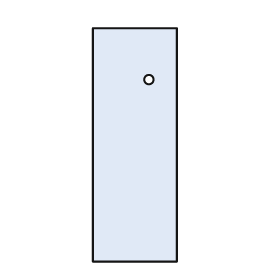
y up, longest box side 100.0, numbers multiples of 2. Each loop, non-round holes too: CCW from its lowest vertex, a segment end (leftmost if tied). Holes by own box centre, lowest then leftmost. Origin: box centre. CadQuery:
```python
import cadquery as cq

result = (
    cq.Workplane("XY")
    .moveTo(-18.0, -50.0)
    .lineTo(18.0, -50.0)
    .lineTo(18.0, 50.0)
    .lineTo(-18.0, 50.0)
    .close()
    .moveTo(6.0, 28.0)
    .circle(2.0)
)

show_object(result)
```